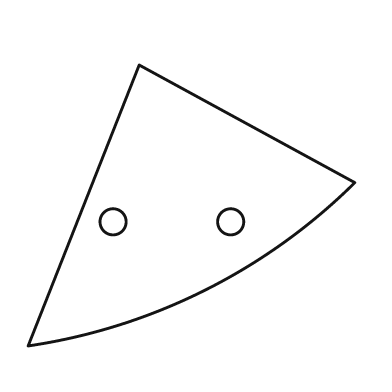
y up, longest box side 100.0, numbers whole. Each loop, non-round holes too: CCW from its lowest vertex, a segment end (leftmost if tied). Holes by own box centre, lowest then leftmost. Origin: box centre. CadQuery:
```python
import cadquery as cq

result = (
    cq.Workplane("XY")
    .moveTo(-50.0, -43.0)
    .threePointArc((4.0, -26.0), (50.0, 7.0))
    .lineTo(-16.0, 43.0)
    .close()
    .moveTo(-24.0, -5.0)
    .circle(4.0)
    .moveTo(12.0, -5.0)
    .circle(4.0)
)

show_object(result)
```